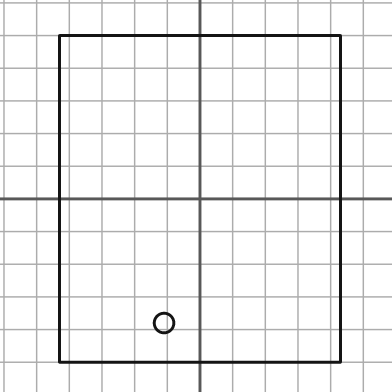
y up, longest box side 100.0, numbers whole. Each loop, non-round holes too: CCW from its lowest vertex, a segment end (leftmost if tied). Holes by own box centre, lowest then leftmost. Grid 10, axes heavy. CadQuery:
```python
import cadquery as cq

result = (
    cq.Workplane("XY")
    .moveTo(-43.0, -50.0)
    .lineTo(43.0, -50.0)
    .lineTo(43.0, 50.0)
    .lineTo(-43.0, 50.0)
    .close()
    .moveTo(-11.0, -38.0)
    .circle(3.0)
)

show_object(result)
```